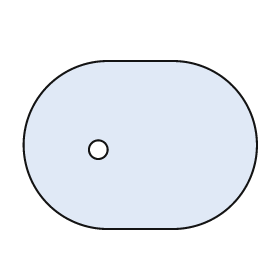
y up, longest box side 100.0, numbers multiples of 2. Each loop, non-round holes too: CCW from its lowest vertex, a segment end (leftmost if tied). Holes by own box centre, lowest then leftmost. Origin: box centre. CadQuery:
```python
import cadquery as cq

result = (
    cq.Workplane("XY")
    .moveTo(-14.0, -36.0)
    .lineTo(14.0, -36.0)
    .threePointArc((50.0, 0.0), (14.0, 36.0))
    .lineTo(-14.0, 36.0)
    .threePointArc((-50.0, 0.0), (-14.0, -36.0))
    .close()
    .moveTo(-18.0, -2.0)
    .circle(4.0)
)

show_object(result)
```